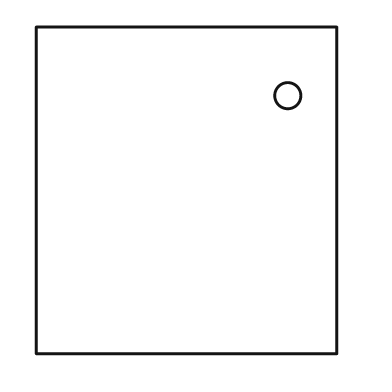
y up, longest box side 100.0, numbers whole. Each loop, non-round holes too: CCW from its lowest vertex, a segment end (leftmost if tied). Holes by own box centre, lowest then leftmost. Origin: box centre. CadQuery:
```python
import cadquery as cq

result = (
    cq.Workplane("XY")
    .moveTo(-46.0, -50.0)
    .lineTo(46.0, -50.0)
    .lineTo(46.0, 50.0)
    .lineTo(-46.0, 50.0)
    .close()
    .moveTo(31.0, 29.0)
    .circle(4.0)
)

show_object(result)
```